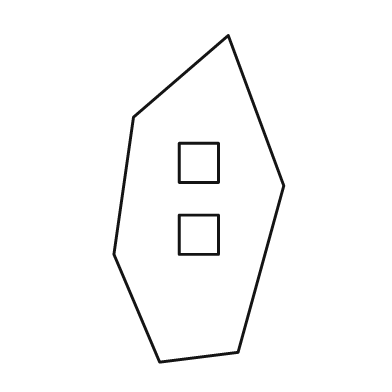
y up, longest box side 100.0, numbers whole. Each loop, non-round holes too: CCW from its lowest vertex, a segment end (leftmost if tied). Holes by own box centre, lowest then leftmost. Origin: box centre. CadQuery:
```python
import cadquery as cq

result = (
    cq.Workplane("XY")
    .moveTo(-12.0, -50.0)
    .lineTo(12.0, -47.0)
    .lineTo(26.0, 4.0)
    .lineTo(9.0, 50.0)
    .lineTo(-20.0, 25.0)
    .lineTo(-26.0, -17.0)
    .close()
    .moveTo(-6.0, -17.0)
    .lineTo(6.0, -17.0)
    .lineTo(6.0, -5.0)
    .lineTo(-6.0, -5.0)
    .close()
    .moveTo(-6.0, 5.0)
    .lineTo(6.0, 5.0)
    .lineTo(6.0, 17.0)
    .lineTo(-6.0, 17.0)
    .close()
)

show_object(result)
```